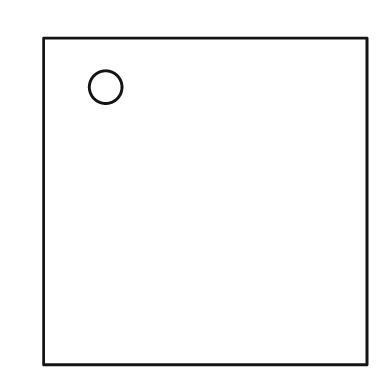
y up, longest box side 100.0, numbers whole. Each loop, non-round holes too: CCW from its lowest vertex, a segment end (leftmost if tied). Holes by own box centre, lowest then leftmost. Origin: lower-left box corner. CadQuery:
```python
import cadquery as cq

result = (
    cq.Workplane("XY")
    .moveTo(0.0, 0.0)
    .lineTo(99.0, 0.0)
    .lineTo(99.0, 100.0)
    .lineTo(0.0, 100.0)
    .close()
    .moveTo(19.0, 85.0)
    .circle(5.0)
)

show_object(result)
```